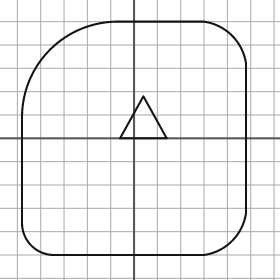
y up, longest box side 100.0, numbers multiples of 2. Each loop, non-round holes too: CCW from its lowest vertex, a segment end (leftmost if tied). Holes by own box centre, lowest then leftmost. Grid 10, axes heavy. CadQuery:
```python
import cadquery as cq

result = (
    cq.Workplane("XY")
    .moveTo(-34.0, -50.0)
    .lineTo(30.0, -50.0)
    .threePointArc((42.0, -44.0), (48.0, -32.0))
    .lineTo(48.0, 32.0)
    .threePointArc((42.0, 44.0), (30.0, 50.0))
    .lineTo(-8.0, 50.0)
    .threePointArc((-36.0, 38.0), (-48.0, 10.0))
    .lineTo(-48.0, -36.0)
    .threePointArc((-44.0, -46.0), (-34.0, -50.0))
    .close()
    .moveTo(-6.0, 0.0)
    .lineTo(14.0, 0.0)
    .lineTo(4.0, 18.0)
    .close()
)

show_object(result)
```